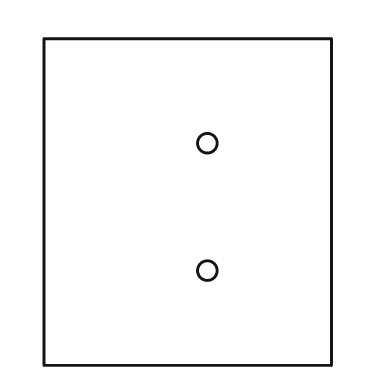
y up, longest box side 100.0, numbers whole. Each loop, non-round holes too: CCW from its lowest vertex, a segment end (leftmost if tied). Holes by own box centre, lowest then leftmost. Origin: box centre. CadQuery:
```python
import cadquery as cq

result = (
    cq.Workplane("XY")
    .moveTo(-44.0, -50.0)
    .lineTo(44.0, -50.0)
    .lineTo(44.0, 50.0)
    .lineTo(-44.0, 50.0)
    .close()
    .moveTo(6.0, -21.0)
    .circle(3.0)
    .moveTo(6.0, 18.0)
    .circle(3.0)
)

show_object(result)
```